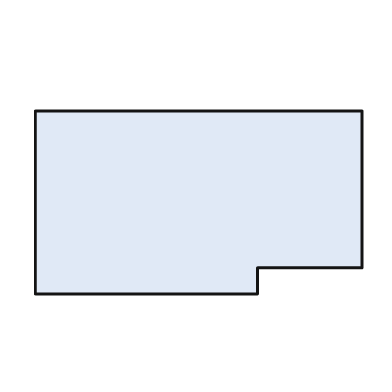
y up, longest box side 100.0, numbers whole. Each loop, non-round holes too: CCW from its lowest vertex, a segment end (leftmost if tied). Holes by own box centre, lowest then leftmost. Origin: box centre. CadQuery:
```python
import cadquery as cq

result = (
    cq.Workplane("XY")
    .moveTo(-50.0, -28.0)
    .lineTo(18.0, -28.0)
    .lineTo(18.0, -20.0)
    .lineTo(50.0, -20.0)
    .lineTo(50.0, 28.0)
    .lineTo(-50.0, 28.0)
    .close()
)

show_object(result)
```